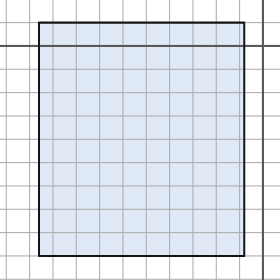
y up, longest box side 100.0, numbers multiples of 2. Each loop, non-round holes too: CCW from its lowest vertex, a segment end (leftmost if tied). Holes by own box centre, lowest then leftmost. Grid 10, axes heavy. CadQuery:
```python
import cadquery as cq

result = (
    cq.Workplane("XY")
    .moveTo(-96.0, -90.0)
    .lineTo(-8.0, -90.0)
    .lineTo(-8.0, 10.0)
    .lineTo(-96.0, 10.0)
    .close()
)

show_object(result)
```